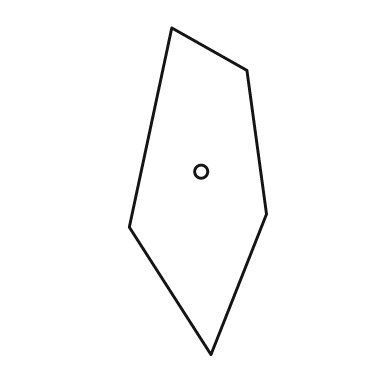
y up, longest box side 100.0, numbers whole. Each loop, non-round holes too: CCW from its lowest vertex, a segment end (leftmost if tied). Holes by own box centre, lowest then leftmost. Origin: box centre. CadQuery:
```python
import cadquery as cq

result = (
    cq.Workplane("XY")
    .moveTo(4.0, -50.0)
    .lineTo(21.0, -7.0)
    .lineTo(15.0, 37.0)
    .lineTo(-8.0, 50.0)
    .lineTo(-21.0, -11.0)
    .close()
    .moveTo(1.0, 6.0)
    .circle(2.0)
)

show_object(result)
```